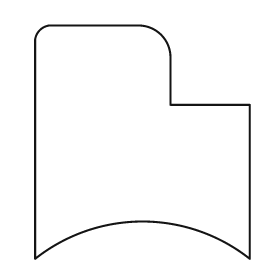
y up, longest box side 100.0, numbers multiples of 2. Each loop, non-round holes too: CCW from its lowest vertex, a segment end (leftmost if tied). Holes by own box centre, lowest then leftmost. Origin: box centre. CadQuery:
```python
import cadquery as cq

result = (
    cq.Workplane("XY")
    .moveTo(-46.0, -50.0)
    .threePointArc((0.0, -34.0), (46.0, -50.0))
    .lineTo(46.0, 16.0)
    .lineTo(12.0, 16.0)
    .lineTo(12.0, 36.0)
    .threePointArc((8.0, 46.0), (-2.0, 50.0))
    .lineTo(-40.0, 50.0)
    .threePointArc((-44.0, 48.0), (-46.0, 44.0))
    .close()
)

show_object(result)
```